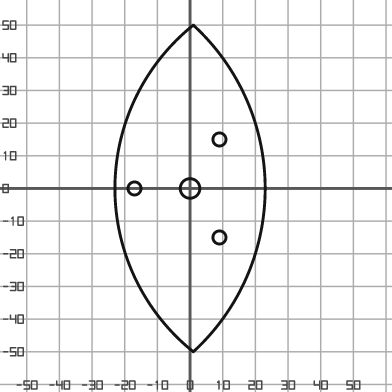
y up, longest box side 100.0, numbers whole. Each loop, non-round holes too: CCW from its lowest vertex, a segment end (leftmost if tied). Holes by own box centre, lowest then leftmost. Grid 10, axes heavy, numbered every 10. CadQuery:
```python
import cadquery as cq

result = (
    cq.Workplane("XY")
    .moveTo(1.0, -50.0)
    .threePointArc((23.0, 0.0), (1.0, 50.0))
    .threePointArc((-23.0, 0.0), (1.0, -50.0))
    .close()
    .moveTo(9.0, -15.0)
    .circle(2.0)
    .moveTo(-17.0, 0.0)
    .circle(2.0)
    .moveTo(0.0, 0.0)
    .circle(3.0)
    .moveTo(9.0, 15.0)
    .circle(2.0)
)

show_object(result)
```